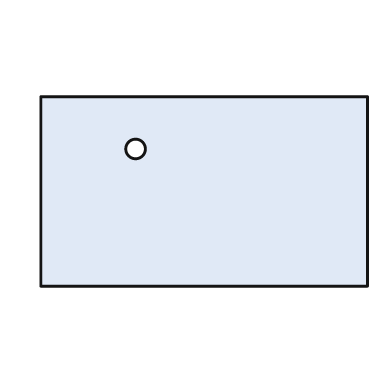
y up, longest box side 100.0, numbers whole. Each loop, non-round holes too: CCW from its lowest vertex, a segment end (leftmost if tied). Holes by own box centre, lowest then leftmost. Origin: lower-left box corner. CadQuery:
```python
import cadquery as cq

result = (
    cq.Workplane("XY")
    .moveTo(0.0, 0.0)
    .lineTo(100.0, 0.0)
    .lineTo(100.0, 58.0)
    .lineTo(0.0, 58.0)
    .close()
    .moveTo(29.0, 42.0)
    .circle(3.0)
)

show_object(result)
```